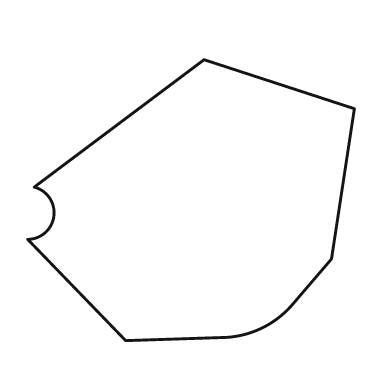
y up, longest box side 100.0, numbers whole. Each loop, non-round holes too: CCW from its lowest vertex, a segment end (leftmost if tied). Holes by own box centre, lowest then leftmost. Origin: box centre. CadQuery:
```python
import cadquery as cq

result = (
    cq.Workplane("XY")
    .moveTo(-20.0, -43.0)
    .lineTo(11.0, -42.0)
    .threePointArc((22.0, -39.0), (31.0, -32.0))
    .lineTo(43.0, -18.0)
    .lineTo(50.0, 28.0)
    .lineTo(4.0, 43.0)
    .lineTo(-48.0, 4.0)
    .threePointArc((-42.0, -5.0), (-50.0, -12.0))
    .close()
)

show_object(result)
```